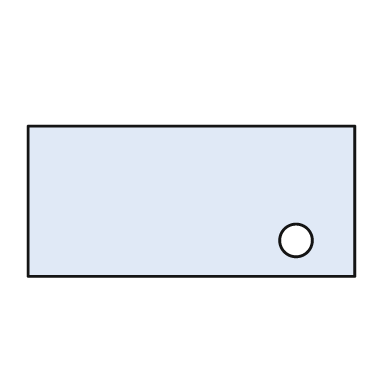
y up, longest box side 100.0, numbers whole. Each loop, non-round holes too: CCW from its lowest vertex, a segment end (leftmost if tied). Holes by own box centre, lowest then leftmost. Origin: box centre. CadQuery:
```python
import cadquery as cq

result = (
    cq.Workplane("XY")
    .moveTo(-50.0, -23.0)
    .lineTo(50.0, -23.0)
    .lineTo(50.0, 23.0)
    .lineTo(-50.0, 23.0)
    .close()
    .moveTo(32.0, -12.0)
    .circle(5.0)
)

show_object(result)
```